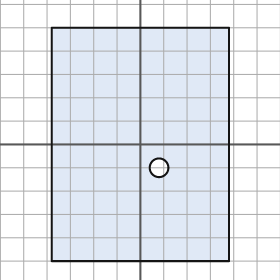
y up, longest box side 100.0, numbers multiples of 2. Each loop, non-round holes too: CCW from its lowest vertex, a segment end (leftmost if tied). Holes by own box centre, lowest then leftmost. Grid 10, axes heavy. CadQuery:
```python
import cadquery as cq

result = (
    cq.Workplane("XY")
    .moveTo(-38.0, -50.0)
    .lineTo(38.0, -50.0)
    .lineTo(38.0, 50.0)
    .lineTo(-38.0, 50.0)
    .close()
    .moveTo(8.0, -10.0)
    .circle(4.0)
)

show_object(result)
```